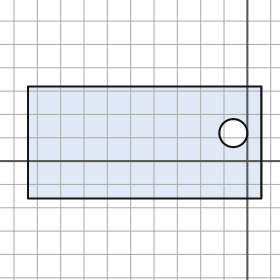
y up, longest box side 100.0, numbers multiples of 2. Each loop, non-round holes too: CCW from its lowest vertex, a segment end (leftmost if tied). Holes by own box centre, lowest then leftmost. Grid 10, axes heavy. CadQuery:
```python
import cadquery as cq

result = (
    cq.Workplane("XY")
    .moveTo(-94.0, -16.0)
    .lineTo(6.0, -16.0)
    .lineTo(6.0, 32.0)
    .lineTo(-94.0, 32.0)
    .close()
    .moveTo(-6.0, 12.0)
    .circle(6.0)
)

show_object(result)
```